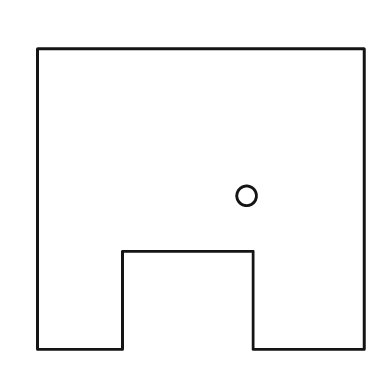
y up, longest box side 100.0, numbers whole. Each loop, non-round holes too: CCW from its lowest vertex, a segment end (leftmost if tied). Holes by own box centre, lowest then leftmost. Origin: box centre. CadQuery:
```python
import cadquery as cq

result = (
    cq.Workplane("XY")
    .moveTo(-50.0, -46.0)
    .lineTo(-24.0, -46.0)
    .lineTo(-24.0, -16.0)
    .lineTo(16.0, -16.0)
    .lineTo(16.0, -46.0)
    .lineTo(50.0, -46.0)
    .lineTo(50.0, 46.0)
    .lineTo(-50.0, 46.0)
    .close()
    .moveTo(14.0, 1.0)
    .circle(3.0)
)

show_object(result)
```